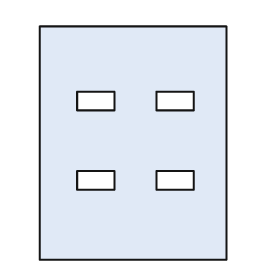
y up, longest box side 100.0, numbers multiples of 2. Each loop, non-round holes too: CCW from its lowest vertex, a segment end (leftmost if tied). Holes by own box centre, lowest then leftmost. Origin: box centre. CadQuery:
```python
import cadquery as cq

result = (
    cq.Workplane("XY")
    .moveTo(-40.0, -50.0)
    .lineTo(40.0, -50.0)
    .lineTo(40.0, 50.0)
    .lineTo(-40.0, 50.0)
    .close()
    .moveTo(-24.0, -20.0)
    .lineTo(-8.0, -20.0)
    .lineTo(-8.0, -12.0)
    .lineTo(-24.0, -12.0)
    .close()
    .moveTo(10.0, -20.0)
    .lineTo(26.0, -20.0)
    .lineTo(26.0, -12.0)
    .lineTo(10.0, -12.0)
    .close()
    .moveTo(-24.0, 14.0)
    .lineTo(-8.0, 14.0)
    .lineTo(-8.0, 22.0)
    .lineTo(-24.0, 22.0)
    .close()
    .moveTo(10.0, 14.0)
    .lineTo(26.0, 14.0)
    .lineTo(26.0, 22.0)
    .lineTo(10.0, 22.0)
    .close()
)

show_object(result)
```